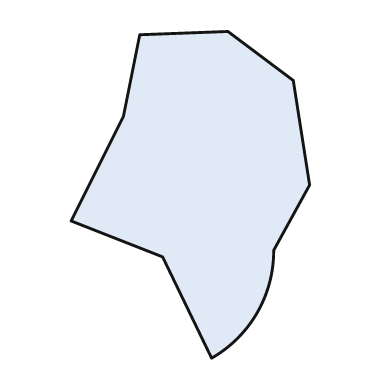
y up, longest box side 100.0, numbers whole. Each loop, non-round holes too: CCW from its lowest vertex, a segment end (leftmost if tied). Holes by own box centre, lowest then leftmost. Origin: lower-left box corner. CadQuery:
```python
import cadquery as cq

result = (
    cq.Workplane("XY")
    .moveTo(43.0, 0.0)
    .threePointArc((57.0, 14.0), (62.0, 33.0))
    .lineTo(73.0, 53.0)
    .lineTo(68.0, 85.0)
    .lineTo(48.0, 100.0)
    .lineTo(21.0, 99.0)
    .lineTo(16.0, 74.0)
    .lineTo(0.0, 42.0)
    .lineTo(28.0, 31.0)
    .close()
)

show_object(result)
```